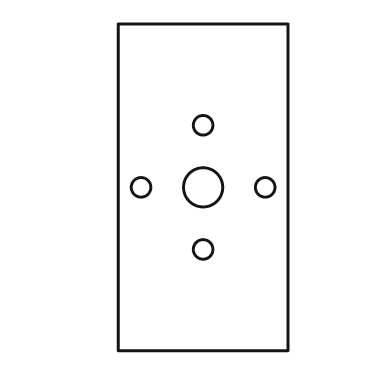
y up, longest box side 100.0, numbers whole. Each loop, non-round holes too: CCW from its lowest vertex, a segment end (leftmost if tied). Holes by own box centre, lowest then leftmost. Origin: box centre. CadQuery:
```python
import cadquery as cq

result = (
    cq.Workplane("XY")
    .moveTo(-26.0, -50.0)
    .lineTo(26.0, -50.0)
    .lineTo(26.0, 50.0)
    .lineTo(-26.0, 50.0)
    .close()
    .moveTo(0.0, -19.0)
    .circle(3.0)
    .moveTo(-19.0, 0.0)
    .circle(3.0)
    .moveTo(0.0, 0.0)
    .circle(6.0)
    .moveTo(19.0, 0.0)
    .circle(3.0)
    .moveTo(0.0, 19.0)
    .circle(3.0)
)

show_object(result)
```